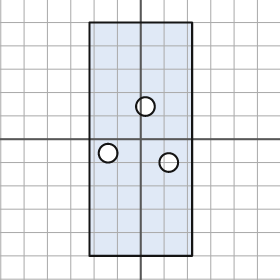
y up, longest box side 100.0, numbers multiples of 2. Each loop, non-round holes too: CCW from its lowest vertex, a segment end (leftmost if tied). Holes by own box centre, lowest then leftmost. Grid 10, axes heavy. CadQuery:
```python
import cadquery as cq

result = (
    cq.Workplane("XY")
    .moveTo(-22.0, -50.0)
    .lineTo(22.0, -50.0)
    .lineTo(22.0, 50.0)
    .lineTo(-22.0, 50.0)
    .close()
    .moveTo(12.0, -10.0)
    .circle(4.0)
    .moveTo(-14.0, -6.0)
    .circle(4.0)
    .moveTo(2.0, 14.0)
    .circle(4.0)
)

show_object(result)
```